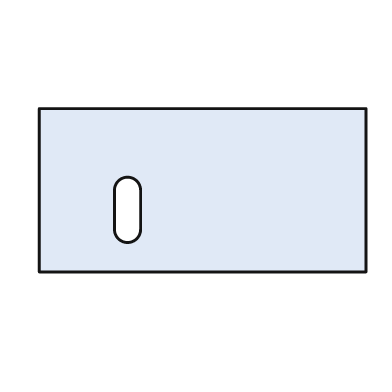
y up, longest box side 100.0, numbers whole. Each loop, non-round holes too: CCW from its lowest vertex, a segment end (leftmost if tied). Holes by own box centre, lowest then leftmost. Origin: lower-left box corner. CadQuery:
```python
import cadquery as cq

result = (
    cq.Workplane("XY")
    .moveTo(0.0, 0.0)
    .lineTo(100.0, 0.0)
    .lineTo(100.0, 50.0)
    .lineTo(0.0, 50.0)
    .close()
    .moveTo(23.0, 13.0)
    .threePointArc((27.0, 9.0), (31.0, 13.0))
    .lineTo(31.0, 25.0)
    .threePointArc((27.0, 29.0), (23.0, 25.0))
    .close()
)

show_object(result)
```